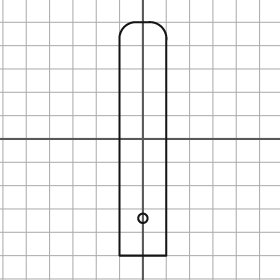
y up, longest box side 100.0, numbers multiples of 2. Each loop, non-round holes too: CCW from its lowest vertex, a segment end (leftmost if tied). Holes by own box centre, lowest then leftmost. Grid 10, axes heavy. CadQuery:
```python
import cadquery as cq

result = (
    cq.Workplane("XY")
    .moveTo(-10.0, -50.0)
    .lineTo(10.0, -50.0)
    .lineTo(10.0, 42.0)
    .threePointArc((8.0, 48.0), (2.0, 50.0))
    .lineTo(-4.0, 50.0)
    .threePointArc((-8.0, 48.0), (-10.0, 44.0))
    .close()
    .moveTo(0.0, -34.0)
    .circle(2.0)
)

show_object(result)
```